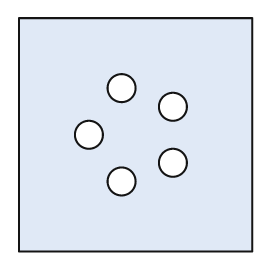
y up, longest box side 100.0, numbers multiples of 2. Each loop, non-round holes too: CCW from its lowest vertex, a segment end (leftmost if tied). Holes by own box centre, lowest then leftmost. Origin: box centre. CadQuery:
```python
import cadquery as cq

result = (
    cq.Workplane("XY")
    .moveTo(-50.0, -50.0)
    .lineTo(50.0, -50.0)
    .lineTo(50.0, 50.0)
    .lineTo(-50.0, 50.0)
    .close()
    .moveTo(-6.0, -20.0)
    .circle(6.0)
    .moveTo(16.0, -12.0)
    .circle(6.0)
    .moveTo(-20.0, 0.0)
    .circle(6.0)
    .moveTo(16.0, 12.0)
    .circle(6.0)
    .moveTo(-6.0, 20.0)
    .circle(6.0)
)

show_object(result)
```